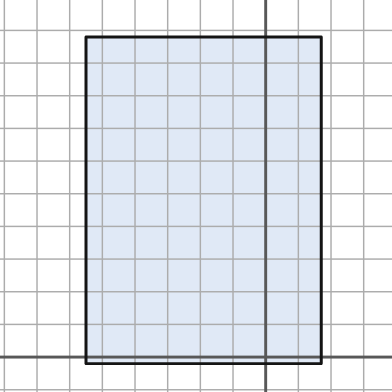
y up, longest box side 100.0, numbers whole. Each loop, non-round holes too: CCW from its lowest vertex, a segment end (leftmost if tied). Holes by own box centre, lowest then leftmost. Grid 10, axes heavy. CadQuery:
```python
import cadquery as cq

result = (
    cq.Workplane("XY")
    .moveTo(-55.0, -2.0)
    .lineTo(17.0, -2.0)
    .lineTo(17.0, 98.0)
    .lineTo(-55.0, 98.0)
    .close()
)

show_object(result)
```